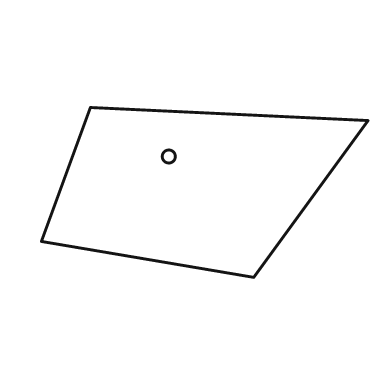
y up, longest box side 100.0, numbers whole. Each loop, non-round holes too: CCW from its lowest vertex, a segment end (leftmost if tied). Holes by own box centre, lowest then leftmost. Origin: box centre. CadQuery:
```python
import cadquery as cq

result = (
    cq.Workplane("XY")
    .moveTo(15.0, -26.0)
    .lineTo(50.0, 22.0)
    .lineTo(-35.0, 26.0)
    .lineTo(-50.0, -15.0)
    .close()
    .moveTo(-11.0, 11.0)
    .circle(2.0)
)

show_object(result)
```